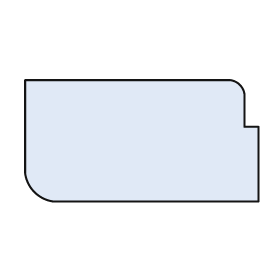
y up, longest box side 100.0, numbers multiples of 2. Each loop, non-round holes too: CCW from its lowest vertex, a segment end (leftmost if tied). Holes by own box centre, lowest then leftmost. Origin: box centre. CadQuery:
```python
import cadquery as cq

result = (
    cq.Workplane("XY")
    .moveTo(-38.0, -26.0)
    .lineTo(50.0, -26.0)
    .lineTo(50.0, 6.0)
    .lineTo(44.0, 6.0)
    .lineTo(44.0, 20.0)
    .threePointArc((42.0, 24.0), (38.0, 26.0))
    .lineTo(-50.0, 26.0)
    .lineTo(-50.0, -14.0)
    .threePointArc((-46.0, -22.0), (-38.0, -26.0))
    .close()
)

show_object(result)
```